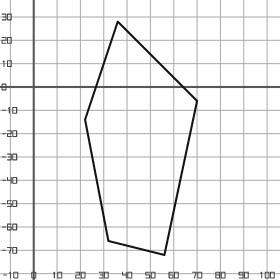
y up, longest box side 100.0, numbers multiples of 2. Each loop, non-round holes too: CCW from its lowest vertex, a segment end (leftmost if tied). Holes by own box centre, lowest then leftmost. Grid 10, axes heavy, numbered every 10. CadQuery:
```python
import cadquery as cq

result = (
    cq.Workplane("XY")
    .moveTo(56.0, -72.0)
    .lineTo(70.0, -6.0)
    .lineTo(36.0, 28.0)
    .lineTo(22.0, -14.0)
    .lineTo(32.0, -66.0)
    .close()
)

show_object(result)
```